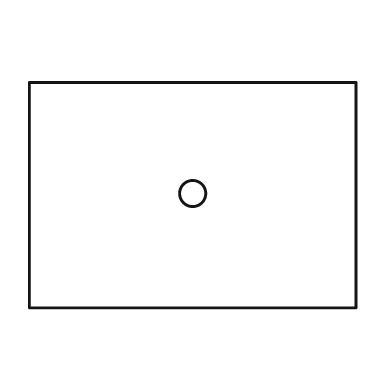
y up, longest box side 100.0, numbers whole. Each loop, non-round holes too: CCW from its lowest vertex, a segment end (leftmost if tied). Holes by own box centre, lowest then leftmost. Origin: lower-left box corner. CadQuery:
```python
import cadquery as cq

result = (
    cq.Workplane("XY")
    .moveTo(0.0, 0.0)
    .lineTo(100.0, 0.0)
    .lineTo(100.0, 69.0)
    .lineTo(0.0, 69.0)
    .close()
    .moveTo(50.0, 35.0)
    .circle(4.0)
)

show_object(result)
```